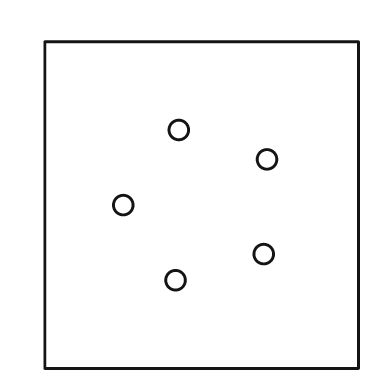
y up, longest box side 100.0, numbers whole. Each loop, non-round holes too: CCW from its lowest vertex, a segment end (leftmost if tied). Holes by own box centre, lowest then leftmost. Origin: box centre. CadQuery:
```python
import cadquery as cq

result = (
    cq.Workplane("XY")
    .moveTo(-48.0, -50.0)
    .lineTo(48.0, -50.0)
    .lineTo(48.0, 50.0)
    .lineTo(-48.0, 50.0)
    .close()
    .moveTo(-8.0, -23.0)
    .circle(3.0)
    .moveTo(19.0, -15.0)
    .circle(3.0)
    .moveTo(-24.0, 0.0)
    .circle(3.0)
    .moveTo(20.0, 14.0)
    .circle(3.0)
    .moveTo(-7.0, 23.0)
    .circle(3.0)
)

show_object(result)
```